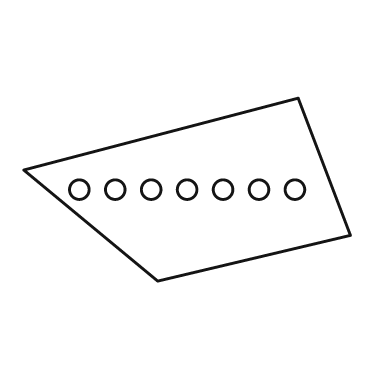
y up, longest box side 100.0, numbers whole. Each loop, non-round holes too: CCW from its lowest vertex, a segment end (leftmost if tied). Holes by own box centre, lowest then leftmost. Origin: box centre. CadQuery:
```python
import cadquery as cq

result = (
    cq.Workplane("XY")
    .moveTo(-9.0, -28.0)
    .lineTo(50.0, -14.0)
    .lineTo(34.0, 28.0)
    .lineTo(-50.0, 6.0)
    .close()
    .moveTo(-33.0, 0.0)
    .circle(3.0)
    .moveTo(-22.0, 0.0)
    .circle(3.0)
    .moveTo(-11.0, 0.0)
    .circle(3.0)
    .moveTo(0.0, 0.0)
    .circle(3.0)
    .moveTo(11.0, 0.0)
    .circle(3.0)
    .moveTo(22.0, 0.0)
    .circle(3.0)
    .moveTo(33.0, 0.0)
    .circle(3.0)
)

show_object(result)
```